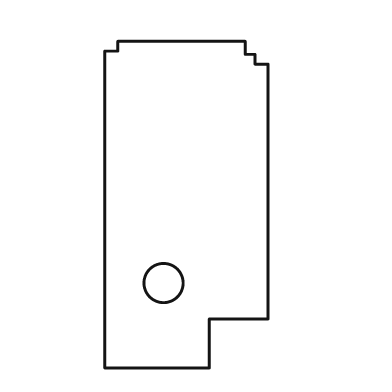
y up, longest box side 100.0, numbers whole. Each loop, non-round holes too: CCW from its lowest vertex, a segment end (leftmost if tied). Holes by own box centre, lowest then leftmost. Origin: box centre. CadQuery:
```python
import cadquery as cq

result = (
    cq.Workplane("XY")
    .moveTo(-25.0, -50.0)
    .lineTo(7.0, -50.0)
    .lineTo(7.0, -35.0)
    .lineTo(25.0, -35.0)
    .lineTo(25.0, 43.0)
    .lineTo(21.0, 43.0)
    .lineTo(21.0, 46.0)
    .lineTo(18.0, 46.0)
    .lineTo(18.0, 50.0)
    .lineTo(-21.0, 50.0)
    .lineTo(-21.0, 47.0)
    .lineTo(-25.0, 47.0)
    .close()
    .moveTo(-7.0, -24.0)
    .circle(6.0)
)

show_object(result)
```